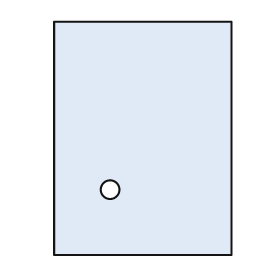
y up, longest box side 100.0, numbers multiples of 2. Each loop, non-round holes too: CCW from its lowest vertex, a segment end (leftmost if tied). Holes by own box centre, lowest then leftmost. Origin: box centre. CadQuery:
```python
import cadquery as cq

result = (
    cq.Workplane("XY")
    .moveTo(-38.0, -50.0)
    .lineTo(38.0, -50.0)
    .lineTo(38.0, 50.0)
    .lineTo(-38.0, 50.0)
    .close()
    .moveTo(-14.0, -22.0)
    .circle(4.0)
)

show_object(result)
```